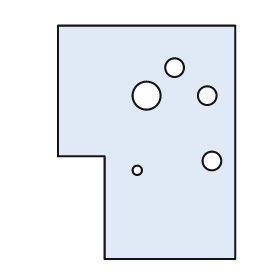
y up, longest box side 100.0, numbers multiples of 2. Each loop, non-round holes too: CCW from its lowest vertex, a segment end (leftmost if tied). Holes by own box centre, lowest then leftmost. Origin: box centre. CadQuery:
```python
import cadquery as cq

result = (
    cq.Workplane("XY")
    .moveTo(-18.0, -50.0)
    .lineTo(38.0, -50.0)
    .lineTo(38.0, 50.0)
    .lineTo(-38.0, 50.0)
    .lineTo(-38.0, -6.0)
    .lineTo(-18.0, -6.0)
    .close()
    .moveTo(-4.0, -12.0)
    .circle(2.0)
    .moveTo(28.0, -8.0)
    .circle(4.0)
    .moveTo(0.0, 20.0)
    .circle(6.0)
    .moveTo(26.0, 20.0)
    .circle(4.0)
    .moveTo(12.0, 32.0)
    .circle(4.0)
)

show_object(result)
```